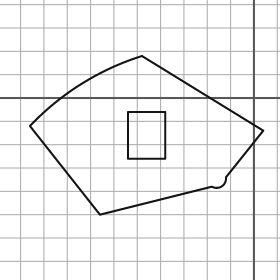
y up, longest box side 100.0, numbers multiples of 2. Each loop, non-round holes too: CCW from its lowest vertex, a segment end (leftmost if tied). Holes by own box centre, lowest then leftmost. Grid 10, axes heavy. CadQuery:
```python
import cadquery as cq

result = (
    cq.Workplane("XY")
    .moveTo(-66.0, -50.0)
    .lineTo(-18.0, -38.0)
    .threePointArc((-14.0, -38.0), (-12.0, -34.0))
    .lineTo(4.0, -14.0)
    .lineTo(-48.0, 18.0)
    .threePointArc((-74.0, 6.0), (-96.0, -12.0))
    .close()
    .moveTo(-54.0, -26.0)
    .lineTo(-38.0, -26.0)
    .lineTo(-38.0, -6.0)
    .lineTo(-54.0, -6.0)
    .close()
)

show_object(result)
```